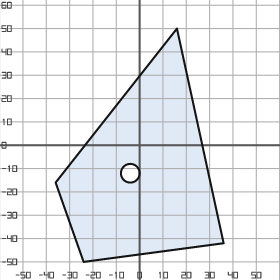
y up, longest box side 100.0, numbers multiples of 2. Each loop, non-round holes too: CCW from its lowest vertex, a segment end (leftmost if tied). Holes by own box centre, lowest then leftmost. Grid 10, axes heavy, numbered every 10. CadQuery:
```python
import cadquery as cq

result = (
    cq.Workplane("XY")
    .moveTo(-24.0, -50.0)
    .lineTo(36.0, -42.0)
    .lineTo(16.0, 50.0)
    .lineTo(-36.0, -16.0)
    .close()
    .moveTo(-4.0, -12.0)
    .circle(4.0)
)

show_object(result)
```